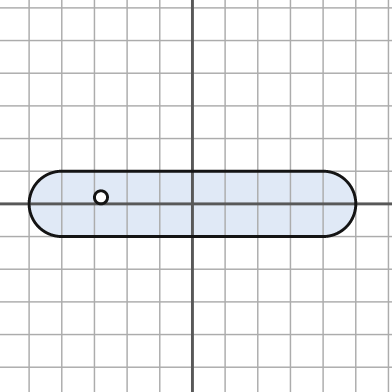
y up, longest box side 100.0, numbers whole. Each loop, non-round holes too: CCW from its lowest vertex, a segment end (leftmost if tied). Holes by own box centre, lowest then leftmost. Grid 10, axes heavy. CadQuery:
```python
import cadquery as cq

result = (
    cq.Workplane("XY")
    .moveTo(-40.0, -10.0)
    .lineTo(40.0, -10.0)
    .threePointArc((50.0, 0.0), (40.0, 10.0))
    .lineTo(-40.0, 10.0)
    .threePointArc((-50.0, 0.0), (-40.0, -10.0))
    .close()
    .moveTo(-28.0, 2.0)
    .circle(2.0)
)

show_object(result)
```